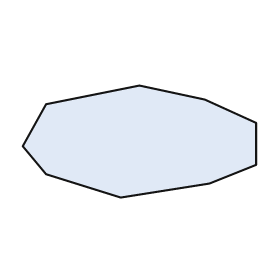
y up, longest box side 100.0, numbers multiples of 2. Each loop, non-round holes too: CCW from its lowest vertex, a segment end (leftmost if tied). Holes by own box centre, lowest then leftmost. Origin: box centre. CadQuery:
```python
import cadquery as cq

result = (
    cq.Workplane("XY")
    .moveTo(-8.0, -24.0)
    .lineTo(30.0, -18.0)
    .lineTo(50.0, -10.0)
    .lineTo(50.0, 8.0)
    .lineTo(28.0, 18.0)
    .lineTo(0.0, 24.0)
    .lineTo(-40.0, 16.0)
    .lineTo(-50.0, -2.0)
    .lineTo(-40.0, -14.0)
    .close()
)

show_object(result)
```